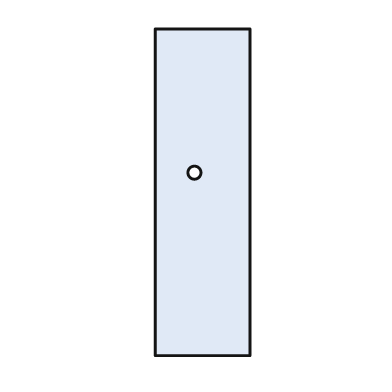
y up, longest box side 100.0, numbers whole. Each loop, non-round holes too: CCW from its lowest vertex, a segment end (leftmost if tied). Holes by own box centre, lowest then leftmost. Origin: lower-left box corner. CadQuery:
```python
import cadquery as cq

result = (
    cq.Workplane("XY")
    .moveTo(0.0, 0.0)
    .lineTo(29.0, 0.0)
    .lineTo(29.0, 100.0)
    .lineTo(0.0, 100.0)
    .close()
    .moveTo(12.0, 56.0)
    .circle(2.0)
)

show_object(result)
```